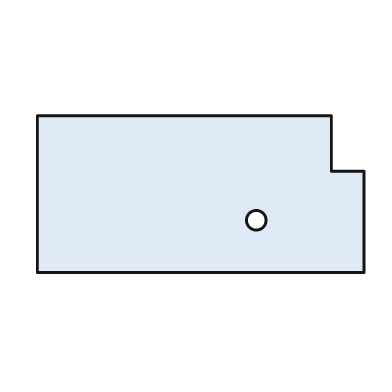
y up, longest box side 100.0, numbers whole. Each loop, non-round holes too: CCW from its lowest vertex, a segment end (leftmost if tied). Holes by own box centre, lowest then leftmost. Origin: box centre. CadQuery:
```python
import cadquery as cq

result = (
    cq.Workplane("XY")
    .moveTo(-50.0, -24.0)
    .lineTo(50.0, -24.0)
    .lineTo(50.0, 7.0)
    .lineTo(40.0, 7.0)
    .lineTo(40.0, 24.0)
    .lineTo(-50.0, 24.0)
    .close()
    .moveTo(17.0, -8.0)
    .circle(3.0)
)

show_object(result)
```